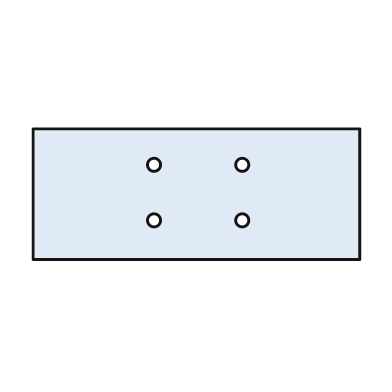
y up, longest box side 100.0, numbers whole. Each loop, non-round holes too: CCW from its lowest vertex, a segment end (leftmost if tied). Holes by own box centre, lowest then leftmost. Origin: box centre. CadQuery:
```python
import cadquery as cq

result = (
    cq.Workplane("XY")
    .moveTo(-50.0, -20.0)
    .lineTo(50.0, -20.0)
    .lineTo(50.0, 20.0)
    .lineTo(-50.0, 20.0)
    .close()
    .moveTo(-13.0, -8.0)
    .circle(2.0)
    .moveTo(14.0, -8.0)
    .circle(2.0)
    .moveTo(-13.0, 9.0)
    .circle(2.0)
    .moveTo(14.0, 9.0)
    .circle(2.0)
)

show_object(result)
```